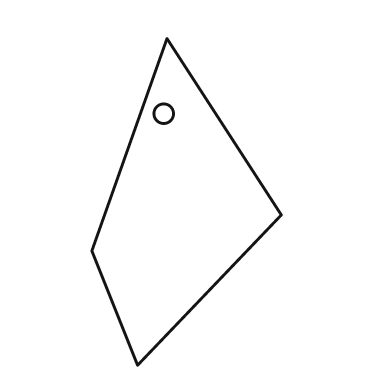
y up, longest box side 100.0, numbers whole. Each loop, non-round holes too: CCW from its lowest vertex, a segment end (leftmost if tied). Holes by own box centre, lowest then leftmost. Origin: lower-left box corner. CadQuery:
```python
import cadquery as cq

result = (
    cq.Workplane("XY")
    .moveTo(14.0, 0.0)
    .lineTo(58.0, 46.0)
    .lineTo(23.0, 100.0)
    .lineTo(0.0, 35.0)
    .close()
    .moveTo(22.0, 77.0)
    .circle(3.0)
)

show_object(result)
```